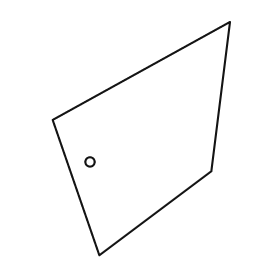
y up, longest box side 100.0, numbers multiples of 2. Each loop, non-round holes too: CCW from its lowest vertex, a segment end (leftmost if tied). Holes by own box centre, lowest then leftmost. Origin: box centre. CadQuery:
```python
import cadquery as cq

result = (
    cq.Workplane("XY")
    .moveTo(-18.0, -50.0)
    .lineTo(30.0, -14.0)
    .lineTo(38.0, 50.0)
    .lineTo(-38.0, 8.0)
    .close()
    .moveTo(-22.0, -10.0)
    .circle(2.0)
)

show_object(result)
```